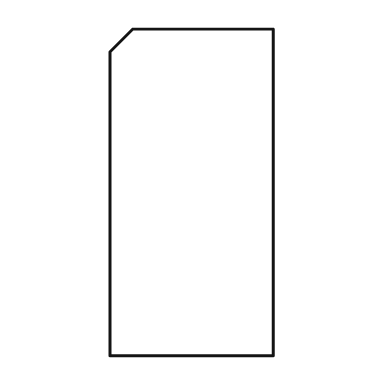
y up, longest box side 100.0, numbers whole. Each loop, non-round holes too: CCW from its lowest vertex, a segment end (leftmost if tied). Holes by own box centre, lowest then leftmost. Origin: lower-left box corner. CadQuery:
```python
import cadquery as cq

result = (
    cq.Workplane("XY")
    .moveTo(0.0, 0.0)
    .lineTo(50.0, 0.0)
    .lineTo(50.0, 100.0)
    .lineTo(7.0, 100.0)
    .lineTo(0.0, 93.0)
    .close()
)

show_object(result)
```